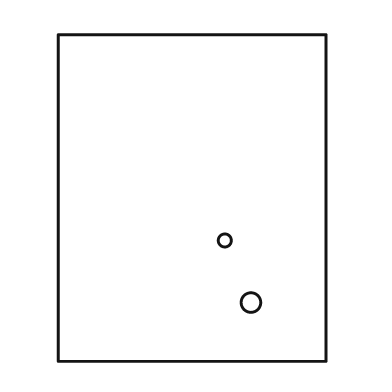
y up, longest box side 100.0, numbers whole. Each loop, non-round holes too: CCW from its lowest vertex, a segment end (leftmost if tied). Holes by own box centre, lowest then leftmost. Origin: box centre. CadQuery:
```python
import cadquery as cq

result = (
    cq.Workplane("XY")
    .moveTo(-41.0, -50.0)
    .lineTo(41.0, -50.0)
    .lineTo(41.0, 50.0)
    .lineTo(-41.0, 50.0)
    .close()
    .moveTo(18.0, -32.0)
    .circle(3.0)
    .moveTo(10.0, -13.0)
    .circle(2.0)
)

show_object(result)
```